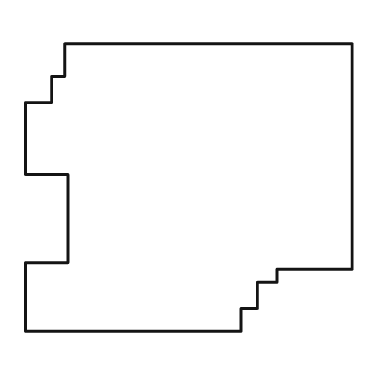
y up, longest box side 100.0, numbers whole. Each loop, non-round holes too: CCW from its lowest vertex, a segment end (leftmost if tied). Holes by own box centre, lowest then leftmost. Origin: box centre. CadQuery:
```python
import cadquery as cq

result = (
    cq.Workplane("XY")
    .moveTo(-50.0, -44.0)
    .lineTo(16.0, -44.0)
    .lineTo(16.0, -37.0)
    .lineTo(21.0, -37.0)
    .lineTo(21.0, -29.0)
    .lineTo(27.0, -29.0)
    .lineTo(27.0, -25.0)
    .lineTo(50.0, -25.0)
    .lineTo(50.0, 44.0)
    .lineTo(-38.0, 44.0)
    .lineTo(-38.0, 34.0)
    .lineTo(-42.0, 34.0)
    .lineTo(-42.0, 26.0)
    .lineTo(-50.0, 26.0)
    .lineTo(-50.0, 4.0)
    .lineTo(-37.0, 4.0)
    .lineTo(-37.0, -23.0)
    .lineTo(-50.0, -23.0)
    .close()
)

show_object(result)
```